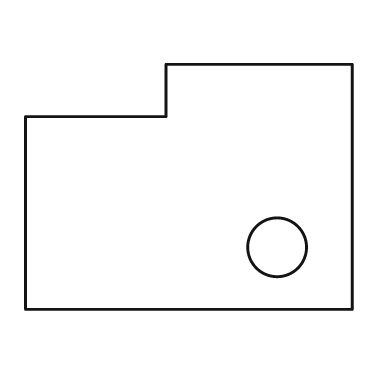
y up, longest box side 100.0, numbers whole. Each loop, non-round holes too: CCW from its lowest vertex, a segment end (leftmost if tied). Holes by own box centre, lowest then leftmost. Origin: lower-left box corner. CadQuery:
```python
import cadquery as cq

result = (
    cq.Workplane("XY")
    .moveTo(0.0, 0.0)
    .lineTo(100.0, 0.0)
    .lineTo(100.0, 75.0)
    .lineTo(43.0, 75.0)
    .lineTo(43.0, 59.0)
    .lineTo(0.0, 59.0)
    .close()
    .moveTo(77.0, 19.0)
    .circle(9.0)
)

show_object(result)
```